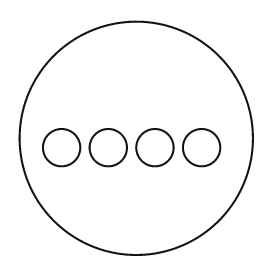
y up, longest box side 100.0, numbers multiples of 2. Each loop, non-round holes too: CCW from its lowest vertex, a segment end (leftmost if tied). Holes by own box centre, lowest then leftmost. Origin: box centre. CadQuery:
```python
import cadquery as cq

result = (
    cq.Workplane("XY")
    .moveTo(0.0, 0.0)
    .circle(50.0)
    .moveTo(-32.0, -4.0)
    .circle(8.0)
    .moveTo(-12.0, -4.0)
    .circle(8.0)
    .moveTo(8.0, -4.0)
    .circle(8.0)
    .moveTo(28.0, -4.0)
    .circle(8.0)
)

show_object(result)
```